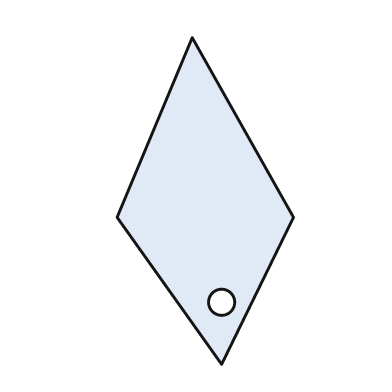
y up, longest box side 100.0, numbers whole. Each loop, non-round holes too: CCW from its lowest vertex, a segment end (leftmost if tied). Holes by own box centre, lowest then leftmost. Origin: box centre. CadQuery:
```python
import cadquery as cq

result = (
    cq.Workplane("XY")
    .moveTo(5.0, -50.0)
    .lineTo(27.0, -5.0)
    .lineTo(-4.0, 50.0)
    .lineTo(-27.0, -5.0)
    .close()
    .moveTo(5.0, -31.0)
    .circle(4.0)
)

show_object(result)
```